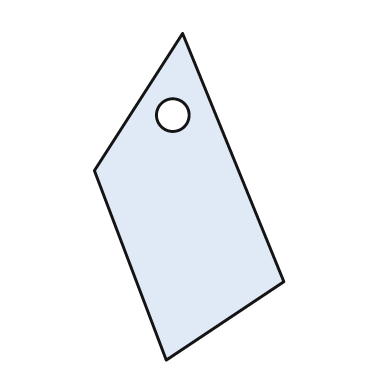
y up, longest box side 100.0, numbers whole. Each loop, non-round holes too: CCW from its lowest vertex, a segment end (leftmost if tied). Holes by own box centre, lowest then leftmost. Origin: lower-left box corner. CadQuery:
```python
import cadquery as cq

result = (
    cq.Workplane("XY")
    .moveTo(22.0, 0.0)
    .lineTo(58.0, 24.0)
    .lineTo(27.0, 100.0)
    .lineTo(0.0, 58.0)
    .close()
    .moveTo(24.0, 75.0)
    .circle(5.0)
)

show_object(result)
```